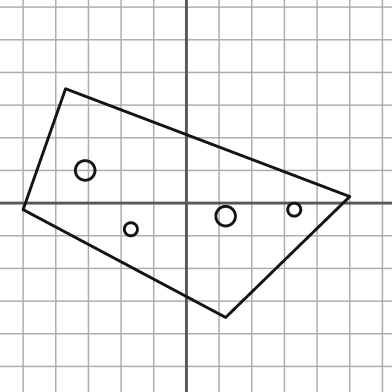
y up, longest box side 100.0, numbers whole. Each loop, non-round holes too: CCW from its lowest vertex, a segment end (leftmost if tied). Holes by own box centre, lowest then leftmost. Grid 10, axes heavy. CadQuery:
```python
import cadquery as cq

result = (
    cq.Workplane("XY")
    .moveTo(12.0, -35.0)
    .lineTo(50.0, 2.0)
    .lineTo(-37.0, 35.0)
    .lineTo(-50.0, -2.0)
    .close()
    .moveTo(-17.0, -8.0)
    .circle(2.0)
    .moveTo(12.0, -4.0)
    .circle(3.0)
    .moveTo(33.0, -2.0)
    .circle(2.0)
    .moveTo(-31.0, 10.0)
    .circle(3.0)
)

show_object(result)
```